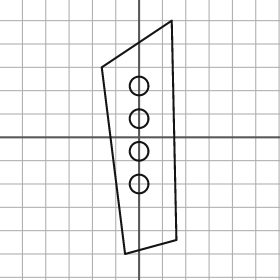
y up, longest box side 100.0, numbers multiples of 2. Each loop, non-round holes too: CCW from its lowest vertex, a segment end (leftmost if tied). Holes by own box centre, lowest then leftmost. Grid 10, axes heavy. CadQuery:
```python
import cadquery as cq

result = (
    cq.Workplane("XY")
    .moveTo(-6.0, -50.0)
    .lineTo(16.0, -44.0)
    .lineTo(14.0, 50.0)
    .lineTo(-16.0, 30.0)
    .close()
    .moveTo(0.0, -20.0)
    .circle(4.0)
    .moveTo(0.0, -6.0)
    .circle(4.0)
    .moveTo(0.0, 8.0)
    .circle(4.0)
    .moveTo(0.0, 22.0)
    .circle(4.0)
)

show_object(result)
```